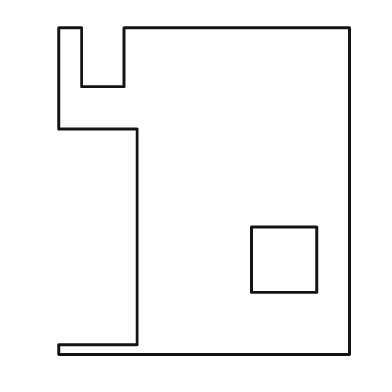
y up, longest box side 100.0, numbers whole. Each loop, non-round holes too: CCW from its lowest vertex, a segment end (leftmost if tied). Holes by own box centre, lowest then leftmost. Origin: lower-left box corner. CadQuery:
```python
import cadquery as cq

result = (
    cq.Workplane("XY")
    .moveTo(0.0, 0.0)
    .lineTo(89.0, 0.0)
    .lineTo(89.0, 100.0)
    .lineTo(20.0, 100.0)
    .lineTo(20.0, 82.0)
    .lineTo(7.0, 82.0)
    .lineTo(7.0, 100.0)
    .lineTo(0.0, 100.0)
    .lineTo(0.0, 69.0)
    .lineTo(24.0, 69.0)
    .lineTo(24.0, 3.0)
    .lineTo(0.0, 3.0)
    .close()
    .moveTo(59.0, 19.0)
    .lineTo(79.0, 19.0)
    .lineTo(79.0, 39.0)
    .lineTo(59.0, 39.0)
    .close()
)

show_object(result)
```